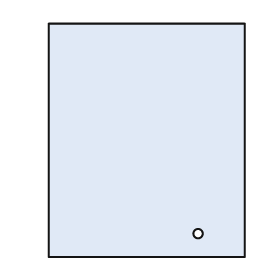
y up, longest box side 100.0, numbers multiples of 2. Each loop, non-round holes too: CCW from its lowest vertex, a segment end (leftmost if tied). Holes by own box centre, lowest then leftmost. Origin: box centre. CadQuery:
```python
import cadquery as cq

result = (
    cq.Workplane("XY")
    .moveTo(-42.0, -50.0)
    .lineTo(42.0, -50.0)
    .lineTo(42.0, 50.0)
    .lineTo(-42.0, 50.0)
    .close()
    .moveTo(22.0, -40.0)
    .circle(2.0)
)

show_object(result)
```